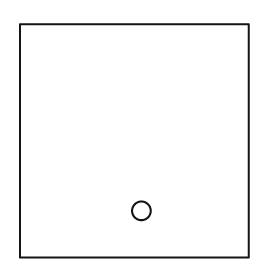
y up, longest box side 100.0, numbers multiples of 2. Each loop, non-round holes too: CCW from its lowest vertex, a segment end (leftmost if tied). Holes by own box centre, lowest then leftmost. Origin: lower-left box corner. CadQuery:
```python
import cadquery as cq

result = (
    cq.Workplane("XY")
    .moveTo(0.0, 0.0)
    .lineTo(98.0, 0.0)
    .lineTo(98.0, 100.0)
    .lineTo(0.0, 100.0)
    .close()
    .moveTo(52.0, 20.0)
    .circle(4.0)
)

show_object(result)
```